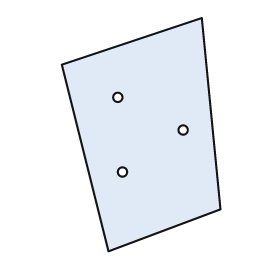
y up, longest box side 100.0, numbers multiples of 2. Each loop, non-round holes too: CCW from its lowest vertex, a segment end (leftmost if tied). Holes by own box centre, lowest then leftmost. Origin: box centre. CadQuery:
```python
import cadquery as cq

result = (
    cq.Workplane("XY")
    .moveTo(-14.0, -50.0)
    .lineTo(34.0, -32.0)
    .lineTo(26.0, 50.0)
    .lineTo(-34.0, 30.0)
    .close()
    .moveTo(-8.0, -16.0)
    .circle(2.0)
    .moveTo(18.0, 2.0)
    .circle(2.0)
    .moveTo(-10.0, 16.0)
    .circle(2.0)
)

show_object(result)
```